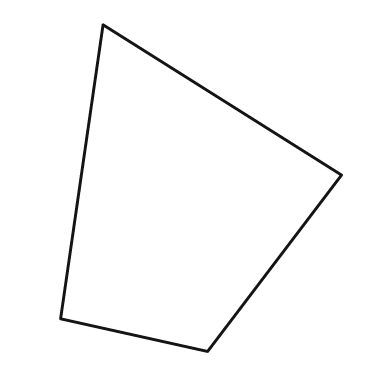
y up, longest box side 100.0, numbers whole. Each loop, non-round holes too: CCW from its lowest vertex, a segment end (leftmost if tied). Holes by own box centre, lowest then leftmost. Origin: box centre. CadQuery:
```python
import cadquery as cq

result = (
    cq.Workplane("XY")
    .moveTo(2.0, -50.0)
    .lineTo(43.0, 4.0)
    .lineTo(-30.0, 50.0)
    .lineTo(-43.0, -40.0)
    .close()
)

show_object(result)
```